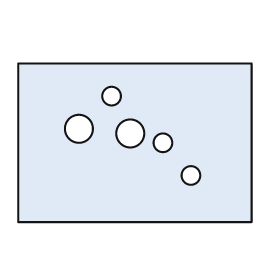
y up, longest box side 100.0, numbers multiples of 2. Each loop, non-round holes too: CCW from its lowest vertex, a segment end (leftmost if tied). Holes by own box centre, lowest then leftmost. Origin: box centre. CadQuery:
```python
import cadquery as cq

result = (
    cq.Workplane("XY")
    .moveTo(-50.0, -34.0)
    .lineTo(50.0, -34.0)
    .lineTo(50.0, 34.0)
    .lineTo(-50.0, 34.0)
    .close()
    .moveTo(24.0, -14.0)
    .circle(4.0)
    .moveTo(12.0, 0.0)
    .circle(4.0)
    .moveTo(-2.0, 4.0)
    .circle(6.0)
    .moveTo(-24.0, 6.0)
    .circle(6.0)
    .moveTo(-10.0, 20.0)
    .circle(4.0)
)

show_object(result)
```